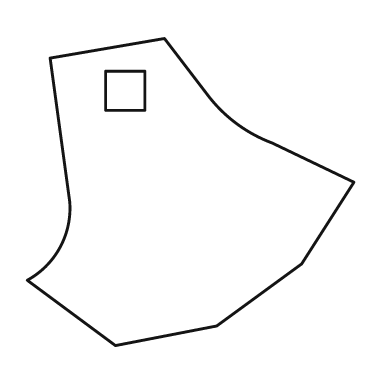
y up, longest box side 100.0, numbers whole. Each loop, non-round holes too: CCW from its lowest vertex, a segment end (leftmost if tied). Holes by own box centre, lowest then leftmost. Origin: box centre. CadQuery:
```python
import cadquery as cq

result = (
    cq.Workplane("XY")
    .moveTo(-23.0, -47.0)
    .lineTo(8.0, -41.0)
    .lineTo(34.0, -22.0)
    .lineTo(50.0, 3.0)
    .lineTo(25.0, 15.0)
    .threePointArc((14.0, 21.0), (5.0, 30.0))
    .lineTo(-8.0, 47.0)
    .lineTo(-43.0, 41.0)
    .lineTo(-37.0, -3.0)
    .threePointArc((-40.0, -17.0), (-50.0, -27.0))
    .close()
    .moveTo(-26.0, 25.0)
    .lineTo(-14.0, 25.0)
    .lineTo(-14.0, 37.0)
    .lineTo(-26.0, 37.0)
    .close()
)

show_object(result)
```